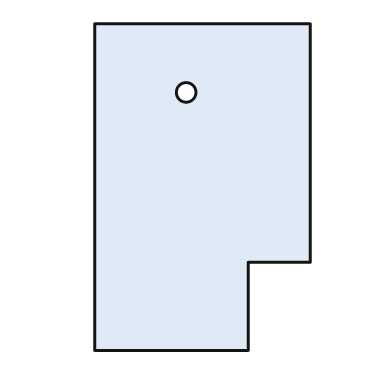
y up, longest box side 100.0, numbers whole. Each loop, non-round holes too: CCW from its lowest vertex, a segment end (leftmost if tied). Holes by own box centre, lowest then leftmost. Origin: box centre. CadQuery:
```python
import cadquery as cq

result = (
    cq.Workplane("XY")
    .moveTo(-33.0, -50.0)
    .lineTo(14.0, -50.0)
    .lineTo(14.0, -23.0)
    .lineTo(33.0, -23.0)
    .lineTo(33.0, 50.0)
    .lineTo(-33.0, 50.0)
    .close()
    .moveTo(-5.0, 29.0)
    .circle(3.0)
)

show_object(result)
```